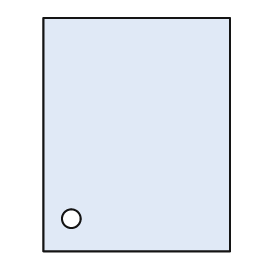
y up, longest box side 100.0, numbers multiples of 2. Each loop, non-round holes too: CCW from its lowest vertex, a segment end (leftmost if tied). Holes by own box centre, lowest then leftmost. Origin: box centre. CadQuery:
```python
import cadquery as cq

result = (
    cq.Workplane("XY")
    .moveTo(-40.0, -50.0)
    .lineTo(40.0, -50.0)
    .lineTo(40.0, 50.0)
    .lineTo(-40.0, 50.0)
    .close()
    .moveTo(-28.0, -36.0)
    .circle(4.0)
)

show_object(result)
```